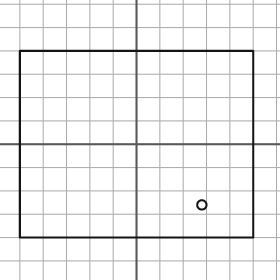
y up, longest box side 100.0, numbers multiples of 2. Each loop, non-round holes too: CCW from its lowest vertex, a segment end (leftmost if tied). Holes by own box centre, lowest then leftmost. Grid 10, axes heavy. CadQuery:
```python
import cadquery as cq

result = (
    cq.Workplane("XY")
    .moveTo(-50.0, -40.0)
    .lineTo(50.0, -40.0)
    .lineTo(50.0, 40.0)
    .lineTo(-50.0, 40.0)
    .close()
    .moveTo(28.0, -26.0)
    .circle(2.0)
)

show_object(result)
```